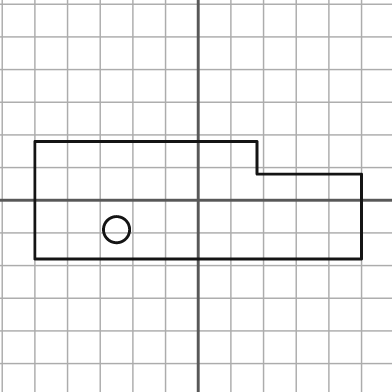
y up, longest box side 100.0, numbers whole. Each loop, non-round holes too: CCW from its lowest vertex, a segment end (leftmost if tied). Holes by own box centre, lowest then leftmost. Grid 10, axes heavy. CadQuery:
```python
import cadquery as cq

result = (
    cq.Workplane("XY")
    .moveTo(-50.0, -18.0)
    .lineTo(50.0, -18.0)
    .lineTo(50.0, 8.0)
    .lineTo(18.0, 8.0)
    .lineTo(18.0, 18.0)
    .lineTo(-50.0, 18.0)
    .close()
    .moveTo(-25.0, -9.0)
    .circle(4.0)
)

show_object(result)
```